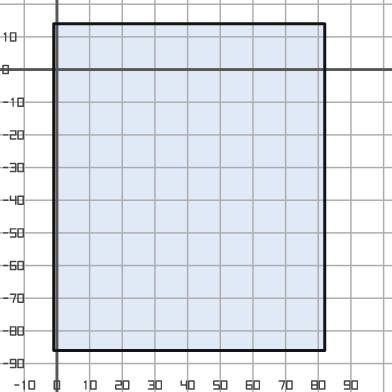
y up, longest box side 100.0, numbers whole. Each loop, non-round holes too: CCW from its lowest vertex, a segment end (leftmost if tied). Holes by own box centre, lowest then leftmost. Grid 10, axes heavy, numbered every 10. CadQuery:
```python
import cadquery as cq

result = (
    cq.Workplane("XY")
    .moveTo(-1.0, -86.0)
    .lineTo(82.0, -86.0)
    .lineTo(82.0, 14.0)
    .lineTo(-1.0, 14.0)
    .close()
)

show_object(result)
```